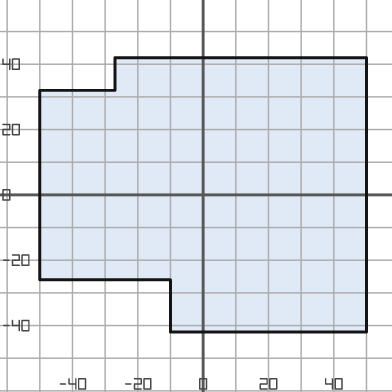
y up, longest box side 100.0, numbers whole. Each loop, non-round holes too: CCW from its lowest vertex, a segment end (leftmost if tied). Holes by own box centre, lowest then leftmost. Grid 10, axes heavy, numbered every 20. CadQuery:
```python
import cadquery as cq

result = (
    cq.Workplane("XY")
    .moveTo(-10.0, -42.0)
    .lineTo(50.0, -42.0)
    .lineTo(50.0, 42.0)
    .lineTo(-27.0, 42.0)
    .lineTo(-27.0, 32.0)
    .lineTo(-50.0, 32.0)
    .lineTo(-50.0, -26.0)
    .lineTo(-10.0, -26.0)
    .close()
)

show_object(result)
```